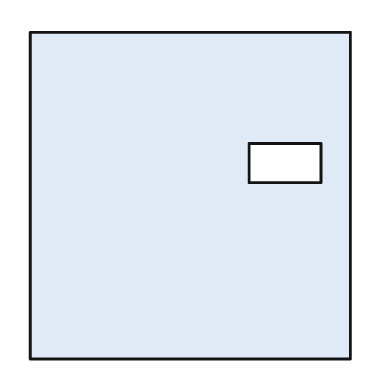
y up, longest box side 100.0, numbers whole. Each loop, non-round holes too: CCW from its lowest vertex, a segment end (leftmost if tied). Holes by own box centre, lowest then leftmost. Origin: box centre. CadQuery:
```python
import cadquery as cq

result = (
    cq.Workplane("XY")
    .moveTo(-49.0, -50.0)
    .lineTo(49.0, -50.0)
    .lineTo(49.0, 50.0)
    .lineTo(-49.0, 50.0)
    .close()
    .moveTo(18.0, 4.0)
    .lineTo(40.0, 4.0)
    .lineTo(40.0, 16.0)
    .lineTo(18.0, 16.0)
    .close()
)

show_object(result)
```